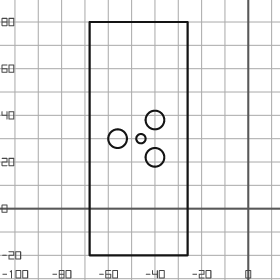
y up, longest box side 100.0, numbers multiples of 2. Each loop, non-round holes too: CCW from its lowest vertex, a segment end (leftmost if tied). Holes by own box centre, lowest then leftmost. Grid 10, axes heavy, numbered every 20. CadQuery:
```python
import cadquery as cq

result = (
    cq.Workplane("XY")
    .moveTo(-68.0, -20.0)
    .lineTo(-26.0, -20.0)
    .lineTo(-26.0, 80.0)
    .lineTo(-68.0, 80.0)
    .close()
    .moveTo(-40.0, 22.0)
    .circle(4.0)
    .moveTo(-56.0, 30.0)
    .circle(4.0)
    .moveTo(-46.0, 30.0)
    .circle(2.0)
    .moveTo(-40.0, 38.0)
    .circle(4.0)
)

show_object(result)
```